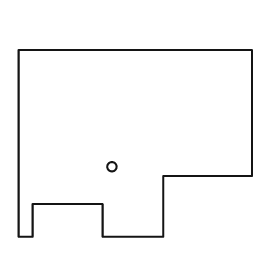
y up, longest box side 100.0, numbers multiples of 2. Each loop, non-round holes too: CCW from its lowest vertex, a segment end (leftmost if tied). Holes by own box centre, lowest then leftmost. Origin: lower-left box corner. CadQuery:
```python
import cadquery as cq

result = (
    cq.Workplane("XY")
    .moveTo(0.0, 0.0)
    .lineTo(6.0, 0.0)
    .lineTo(6.0, 14.0)
    .lineTo(36.0, 14.0)
    .lineTo(36.0, 0.0)
    .lineTo(62.0, 0.0)
    .lineTo(62.0, 26.0)
    .lineTo(100.0, 26.0)
    .lineTo(100.0, 80.0)
    .lineTo(0.0, 80.0)
    .close()
    .moveTo(40.0, 30.0)
    .circle(2.0)
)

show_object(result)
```